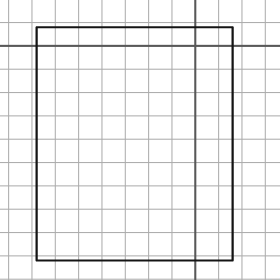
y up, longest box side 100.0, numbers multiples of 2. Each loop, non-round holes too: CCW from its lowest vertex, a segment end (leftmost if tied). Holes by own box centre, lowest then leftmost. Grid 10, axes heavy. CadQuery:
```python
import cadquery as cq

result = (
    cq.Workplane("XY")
    .moveTo(-68.0, -92.0)
    .lineTo(16.0, -92.0)
    .lineTo(16.0, 8.0)
    .lineTo(-68.0, 8.0)
    .close()
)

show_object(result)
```